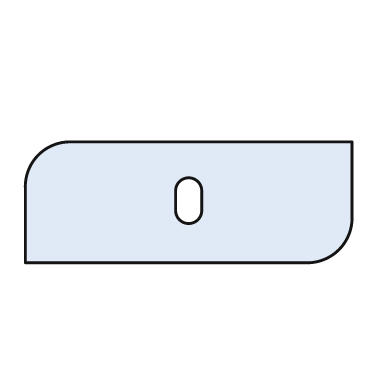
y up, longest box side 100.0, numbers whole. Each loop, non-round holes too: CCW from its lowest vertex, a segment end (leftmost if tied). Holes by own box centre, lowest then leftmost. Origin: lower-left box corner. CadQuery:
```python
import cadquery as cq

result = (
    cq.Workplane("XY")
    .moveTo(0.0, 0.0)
    .lineTo(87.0, 0.0)
    .threePointArc((96.0, 4.0), (100.0, 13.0))
    .lineTo(100.0, 37.0)
    .lineTo(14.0, 37.0)
    .threePointArc((4.0, 33.0), (0.0, 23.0))
    .close()
    .moveTo(46.0, 16.0)
    .threePointArc((50.0, 12.0), (54.0, 16.0))
    .lineTo(54.0, 22.0)
    .threePointArc((50.0, 26.0), (46.0, 22.0))
    .close()
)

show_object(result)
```